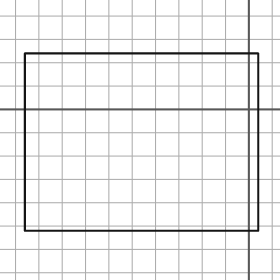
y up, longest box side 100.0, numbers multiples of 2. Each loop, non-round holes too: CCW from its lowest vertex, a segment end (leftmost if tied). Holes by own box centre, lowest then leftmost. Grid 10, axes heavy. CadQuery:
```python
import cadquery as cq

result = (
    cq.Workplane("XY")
    .moveTo(-96.0, -52.0)
    .lineTo(4.0, -52.0)
    .lineTo(4.0, 24.0)
    .lineTo(-96.0, 24.0)
    .close()
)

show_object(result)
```